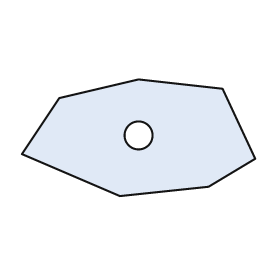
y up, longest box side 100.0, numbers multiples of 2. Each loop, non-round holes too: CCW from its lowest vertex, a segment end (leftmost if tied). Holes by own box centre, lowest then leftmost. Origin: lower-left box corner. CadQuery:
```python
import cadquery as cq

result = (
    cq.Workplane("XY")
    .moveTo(42.0, 0.0)
    .lineTo(80.0, 4.0)
    .lineTo(100.0, 16.0)
    .lineTo(86.0, 46.0)
    .lineTo(50.0, 50.0)
    .lineTo(16.0, 42.0)
    .lineTo(0.0, 18.0)
    .close()
    .moveTo(50.0, 26.0)
    .circle(6.0)
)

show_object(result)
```